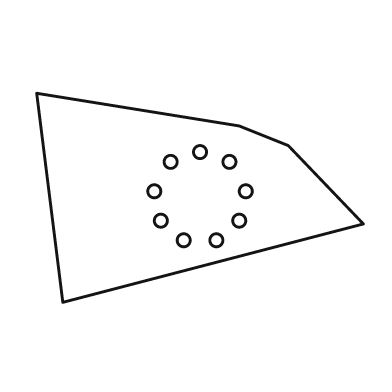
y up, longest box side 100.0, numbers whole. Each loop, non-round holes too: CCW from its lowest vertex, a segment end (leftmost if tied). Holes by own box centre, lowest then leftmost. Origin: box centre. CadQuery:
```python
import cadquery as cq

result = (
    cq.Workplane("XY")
    .moveTo(-42.0, -32.0)
    .lineTo(50.0, -8.0)
    .lineTo(27.0, 16.0)
    .lineTo(12.0, 22.0)
    .lineTo(-50.0, 32.0)
    .close()
    .moveTo(-5.0, -13.0)
    .circle(2.0)
    .moveTo(5.0, -13.0)
    .circle(2.0)
    .moveTo(-12.0, -7.0)
    .circle(2.0)
    .moveTo(12.0, -7.0)
    .circle(2.0)
    .moveTo(-14.0, 2.0)
    .circle(2.0)
    .moveTo(14.0, 2.0)
    .circle(2.0)
    .moveTo(-9.0, 11.0)
    .circle(2.0)
    .moveTo(9.0, 11.0)
    .circle(2.0)
    .moveTo(0.0, 14.0)
    .circle(2.0)
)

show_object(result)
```